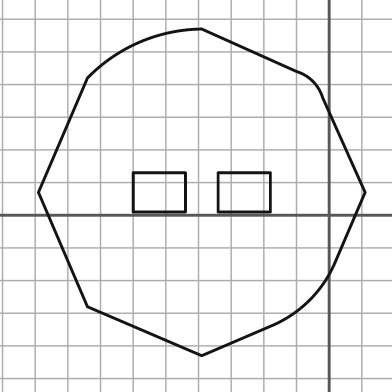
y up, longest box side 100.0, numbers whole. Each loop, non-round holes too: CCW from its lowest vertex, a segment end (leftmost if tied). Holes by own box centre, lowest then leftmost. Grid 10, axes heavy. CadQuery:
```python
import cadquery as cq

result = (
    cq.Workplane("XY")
    .moveTo(-39.0, -43.0)
    .lineTo(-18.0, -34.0)
    .threePointArc((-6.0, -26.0), (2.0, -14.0))
    .lineTo(11.0, 7.0)
    .lineTo(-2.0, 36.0)
    .threePointArc((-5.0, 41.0), (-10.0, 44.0))
    .lineTo(-39.0, 57.0)
    .threePointArc((-58.0, 53.0), (-74.0, 42.0))
    .lineTo(-89.0, 7.0)
    .lineTo(-74.0, -28.0)
    .close()
    .moveTo(-60.0, 1.0)
    .lineTo(-44.0, 1.0)
    .lineTo(-44.0, 13.0)
    .lineTo(-60.0, 13.0)
    .close()
    .moveTo(-34.0, 1.0)
    .lineTo(-18.0, 1.0)
    .lineTo(-18.0, 13.0)
    .lineTo(-34.0, 13.0)
    .close()
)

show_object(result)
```